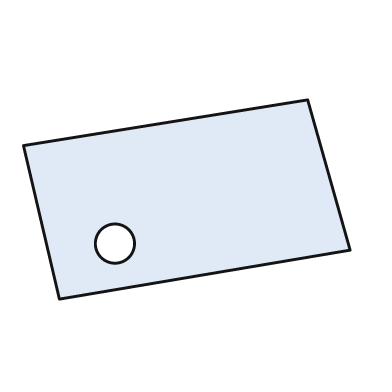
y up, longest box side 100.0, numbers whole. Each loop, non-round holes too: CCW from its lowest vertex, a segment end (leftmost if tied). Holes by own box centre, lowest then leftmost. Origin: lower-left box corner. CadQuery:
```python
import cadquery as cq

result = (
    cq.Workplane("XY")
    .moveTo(11.0, 0.0)
    .lineTo(100.0, 15.0)
    .lineTo(87.0, 61.0)
    .lineTo(0.0, 47.0)
    .close()
    .moveTo(28.0, 17.0)
    .circle(6.0)
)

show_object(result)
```